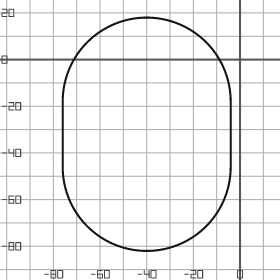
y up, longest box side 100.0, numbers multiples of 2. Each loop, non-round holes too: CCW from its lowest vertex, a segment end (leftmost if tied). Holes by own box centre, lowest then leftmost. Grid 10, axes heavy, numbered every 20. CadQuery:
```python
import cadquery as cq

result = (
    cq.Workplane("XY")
    .moveTo(-76.0, -46.0)
    .threePointArc((-40.0, -82.0), (-4.0, -46.0))
    .lineTo(-4.0, -18.0)
    .threePointArc((-40.0, 18.0), (-76.0, -18.0))
    .close()
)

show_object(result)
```